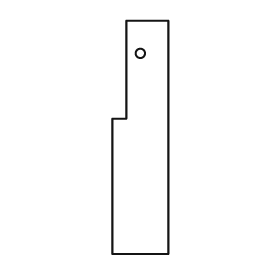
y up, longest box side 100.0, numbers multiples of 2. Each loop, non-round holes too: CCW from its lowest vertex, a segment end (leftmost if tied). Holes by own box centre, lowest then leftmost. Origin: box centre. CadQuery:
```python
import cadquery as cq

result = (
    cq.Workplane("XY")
    .moveTo(-12.0, -50.0)
    .lineTo(12.0, -50.0)
    .lineTo(12.0, 50.0)
    .lineTo(-6.0, 50.0)
    .lineTo(-6.0, 8.0)
    .lineTo(-12.0, 8.0)
    .close()
    .moveTo(0.0, 36.0)
    .circle(2.0)
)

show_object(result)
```